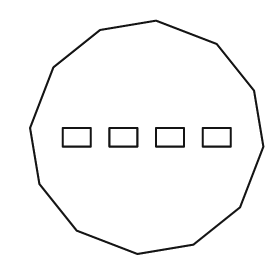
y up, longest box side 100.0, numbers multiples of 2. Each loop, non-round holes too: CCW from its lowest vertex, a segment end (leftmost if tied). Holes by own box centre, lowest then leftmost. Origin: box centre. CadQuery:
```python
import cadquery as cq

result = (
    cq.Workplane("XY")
    .moveTo(-4.0, -50.0)
    .lineTo(20.0, -46.0)
    .lineTo(40.0, -30.0)
    .lineTo(50.0, -4.0)
    .lineTo(46.0, 20.0)
    .lineTo(30.0, 40.0)
    .lineTo(4.0, 50.0)
    .lineTo(-20.0, 46.0)
    .lineTo(-40.0, 30.0)
    .lineTo(-50.0, 4.0)
    .lineTo(-46.0, -20.0)
    .lineTo(-30.0, -40.0)
    .close()
    .moveTo(-36.0, -4.0)
    .lineTo(-24.0, -4.0)
    .lineTo(-24.0, 4.0)
    .lineTo(-36.0, 4.0)
    .close()
    .moveTo(-16.0, -4.0)
    .lineTo(-4.0, -4.0)
    .lineTo(-4.0, 4.0)
    .lineTo(-16.0, 4.0)
    .close()
    .moveTo(4.0, -4.0)
    .lineTo(16.0, -4.0)
    .lineTo(16.0, 4.0)
    .lineTo(4.0, 4.0)
    .close()
    .moveTo(24.0, -4.0)
    .lineTo(36.0, -4.0)
    .lineTo(36.0, 4.0)
    .lineTo(24.0, 4.0)
    .close()
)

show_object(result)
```